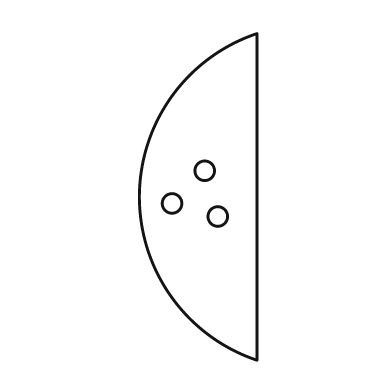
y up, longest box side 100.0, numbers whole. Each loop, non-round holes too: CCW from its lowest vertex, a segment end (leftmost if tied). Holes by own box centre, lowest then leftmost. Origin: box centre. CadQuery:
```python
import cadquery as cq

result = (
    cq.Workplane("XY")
    .moveTo(18.0, -50.0)
    .lineTo(18.0, 50.0)
    .threePointArc((-18.0, 0.0), (18.0, -50.0))
    .close()
    .moveTo(6.0, -6.0)
    .circle(3.0)
    .moveTo(-8.0, -2.0)
    .circle(3.0)
    .moveTo(2.0, 8.0)
    .circle(3.0)
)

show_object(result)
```